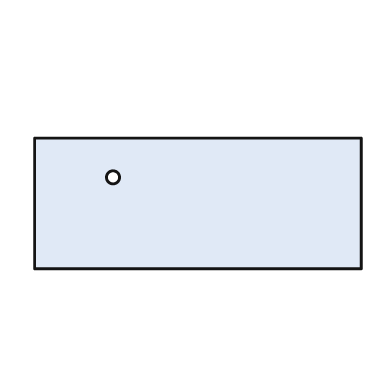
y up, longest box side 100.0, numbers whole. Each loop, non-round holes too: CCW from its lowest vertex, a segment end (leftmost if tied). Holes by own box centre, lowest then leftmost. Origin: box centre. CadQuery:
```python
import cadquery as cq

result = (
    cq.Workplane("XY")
    .moveTo(-50.0, -20.0)
    .lineTo(50.0, -20.0)
    .lineTo(50.0, 20.0)
    .lineTo(-50.0, 20.0)
    .close()
    .moveTo(-26.0, 8.0)
    .circle(2.0)
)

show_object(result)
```